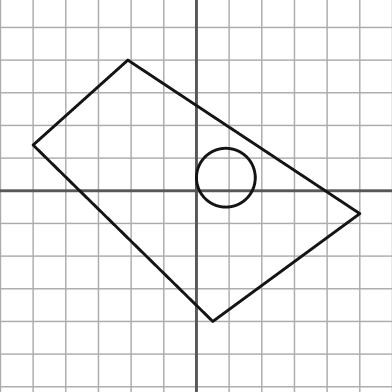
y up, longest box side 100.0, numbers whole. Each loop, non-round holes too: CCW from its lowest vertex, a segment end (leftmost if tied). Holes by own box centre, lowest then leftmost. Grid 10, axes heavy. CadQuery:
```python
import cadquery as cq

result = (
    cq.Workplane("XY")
    .moveTo(5.0, -40.0)
    .lineTo(50.0, -7.0)
    .lineTo(-21.0, 40.0)
    .lineTo(-50.0, 14.0)
    .close()
    .moveTo(9.0, 4.0)
    .circle(9.0)
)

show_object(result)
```